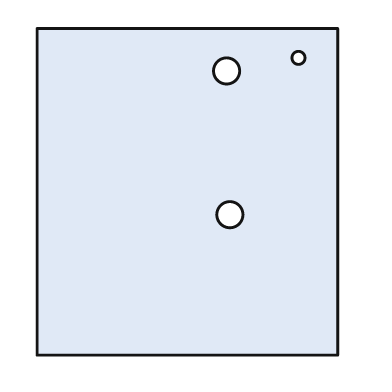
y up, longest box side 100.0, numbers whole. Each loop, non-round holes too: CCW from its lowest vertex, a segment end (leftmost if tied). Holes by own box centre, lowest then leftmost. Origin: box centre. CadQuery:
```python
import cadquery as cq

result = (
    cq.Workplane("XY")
    .moveTo(-46.0, -50.0)
    .lineTo(46.0, -50.0)
    .lineTo(46.0, 50.0)
    .lineTo(-46.0, 50.0)
    .close()
    .moveTo(13.0, -7.0)
    .circle(4.0)
    .moveTo(12.0, 37.0)
    .circle(4.0)
    .moveTo(34.0, 41.0)
    .circle(2.0)
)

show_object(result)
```